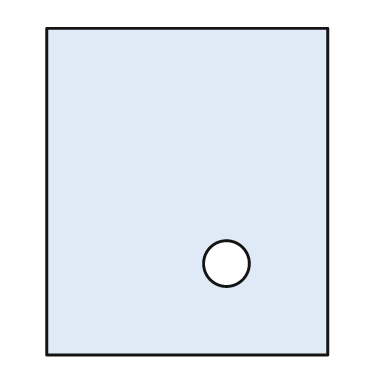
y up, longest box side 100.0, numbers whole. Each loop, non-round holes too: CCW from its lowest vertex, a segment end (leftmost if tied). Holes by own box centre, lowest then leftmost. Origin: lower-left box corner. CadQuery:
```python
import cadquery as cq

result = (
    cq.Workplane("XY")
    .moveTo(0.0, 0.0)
    .lineTo(86.0, 0.0)
    .lineTo(86.0, 100.0)
    .lineTo(0.0, 100.0)
    .close()
    .moveTo(55.0, 28.0)
    .circle(7.0)
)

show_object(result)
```